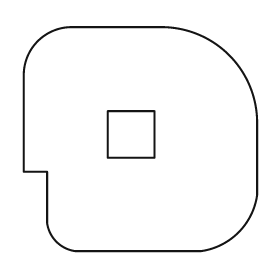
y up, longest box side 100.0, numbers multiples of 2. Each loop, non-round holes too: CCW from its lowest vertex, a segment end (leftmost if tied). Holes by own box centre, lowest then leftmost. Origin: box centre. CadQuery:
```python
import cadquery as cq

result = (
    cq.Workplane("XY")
    .moveTo(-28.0, -48.0)
    .lineTo(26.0, -48.0)
    .threePointArc((42.0, -40.0), (50.0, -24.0))
    .lineTo(50.0, 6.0)
    .threePointArc((38.0, 36.0), (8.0, 48.0))
    .lineTo(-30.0, 48.0)
    .threePointArc((-44.0, 42.0), (-50.0, 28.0))
    .lineTo(-50.0, -14.0)
    .lineTo(-40.0, -14.0)
    .lineTo(-40.0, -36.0)
    .threePointArc((-36.0, -44.0), (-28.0, -48.0))
    .close()
    .moveTo(-14.0, -8.0)
    .lineTo(6.0, -8.0)
    .lineTo(6.0, 12.0)
    .lineTo(-14.0, 12.0)
    .close()
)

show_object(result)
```